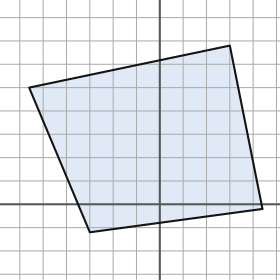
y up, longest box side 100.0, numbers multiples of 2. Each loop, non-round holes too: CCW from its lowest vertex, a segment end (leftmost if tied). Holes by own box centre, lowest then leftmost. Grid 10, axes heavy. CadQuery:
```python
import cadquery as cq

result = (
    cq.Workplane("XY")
    .moveTo(-30.0, -12.0)
    .lineTo(44.0, -2.0)
    .lineTo(30.0, 68.0)
    .lineTo(-56.0, 50.0)
    .close()
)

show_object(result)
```